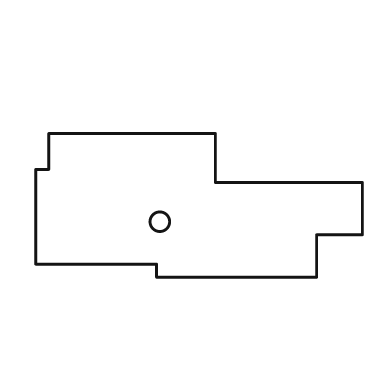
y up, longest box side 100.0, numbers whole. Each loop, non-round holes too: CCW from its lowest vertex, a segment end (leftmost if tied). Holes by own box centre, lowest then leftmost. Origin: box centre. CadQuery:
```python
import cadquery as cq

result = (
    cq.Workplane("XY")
    .moveTo(-13.0, -22.0)
    .lineTo(36.0, -22.0)
    .lineTo(36.0, -9.0)
    .lineTo(50.0, -9.0)
    .lineTo(50.0, 7.0)
    .lineTo(5.0, 7.0)
    .lineTo(5.0, 22.0)
    .lineTo(-46.0, 22.0)
    .lineTo(-46.0, 11.0)
    .lineTo(-50.0, 11.0)
    .lineTo(-50.0, -18.0)
    .lineTo(-13.0, -18.0)
    .close()
    .moveTo(-12.0, -5.0)
    .circle(3.0)
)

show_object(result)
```